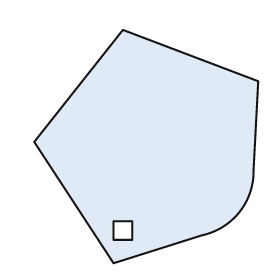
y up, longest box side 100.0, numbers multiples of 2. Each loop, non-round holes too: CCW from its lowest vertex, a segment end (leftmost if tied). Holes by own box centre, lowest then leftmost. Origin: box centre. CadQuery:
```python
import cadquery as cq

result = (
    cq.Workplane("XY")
    .moveTo(-14.0, -50.0)
    .lineTo(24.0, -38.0)
    .threePointArc((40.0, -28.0), (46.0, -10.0))
    .lineTo(48.0, 28.0)
    .lineTo(-10.0, 50.0)
    .lineTo(-48.0, 2.0)
    .close()
    .moveTo(-14.0, -40.0)
    .lineTo(-6.0, -40.0)
    .lineTo(-6.0, -32.0)
    .lineTo(-14.0, -32.0)
    .close()
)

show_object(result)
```